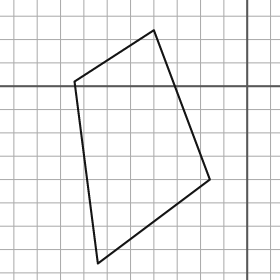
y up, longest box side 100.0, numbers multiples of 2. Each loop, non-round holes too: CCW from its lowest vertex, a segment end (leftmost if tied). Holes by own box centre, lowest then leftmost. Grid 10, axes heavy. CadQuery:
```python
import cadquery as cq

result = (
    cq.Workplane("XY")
    .moveTo(-64.0, -76.0)
    .lineTo(-16.0, -40.0)
    .lineTo(-40.0, 24.0)
    .lineTo(-74.0, 2.0)
    .close()
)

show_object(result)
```